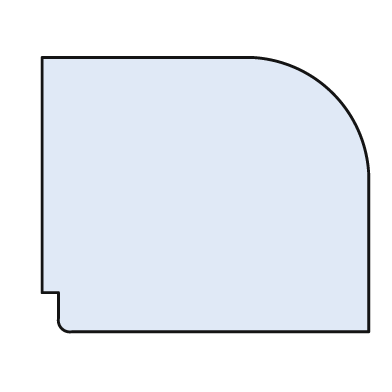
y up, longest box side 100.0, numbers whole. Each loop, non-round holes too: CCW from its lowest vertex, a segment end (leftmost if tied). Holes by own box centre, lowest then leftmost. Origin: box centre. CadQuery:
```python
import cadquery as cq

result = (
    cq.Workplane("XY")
    .moveTo(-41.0, -42.0)
    .lineTo(50.0, -42.0)
    .lineTo(50.0, 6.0)
    .threePointArc((39.0, 31.0), (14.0, 42.0))
    .lineTo(-50.0, 42.0)
    .lineTo(-50.0, -30.0)
    .lineTo(-45.0, -30.0)
    .lineTo(-45.0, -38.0)
    .threePointArc((-44.0, -41.0), (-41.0, -42.0))
    .close()
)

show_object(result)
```